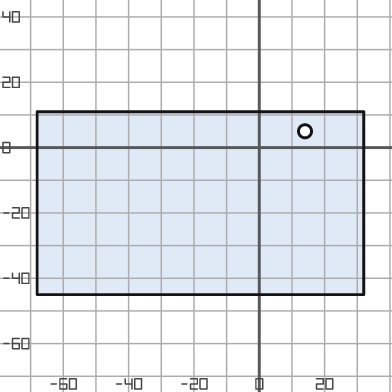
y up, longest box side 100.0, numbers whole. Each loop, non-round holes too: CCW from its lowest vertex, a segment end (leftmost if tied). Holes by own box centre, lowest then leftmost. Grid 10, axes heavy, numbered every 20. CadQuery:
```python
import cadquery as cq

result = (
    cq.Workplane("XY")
    .moveTo(-68.0, -45.0)
    .lineTo(32.0, -45.0)
    .lineTo(32.0, 11.0)
    .lineTo(-68.0, 11.0)
    .close()
    .moveTo(14.0, 5.0)
    .circle(2.0)
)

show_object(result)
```